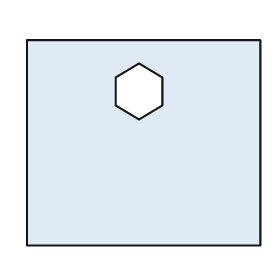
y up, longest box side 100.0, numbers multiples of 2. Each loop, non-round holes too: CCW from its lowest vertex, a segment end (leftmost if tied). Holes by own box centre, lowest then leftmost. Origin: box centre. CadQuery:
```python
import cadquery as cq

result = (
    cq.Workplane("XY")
    .moveTo(-50.0, -44.0)
    .lineTo(50.0, -44.0)
    .lineTo(50.0, 44.0)
    .lineTo(-50.0, 44.0)
    .close()
    .moveTo(-2.0, 10.0)
    .lineTo(8.0, 16.0)
    .lineTo(8.0, 28.0)
    .lineTo(-2.0, 34.0)
    .lineTo(-12.0, 28.0)
    .lineTo(-12.0, 16.0)
    .close()
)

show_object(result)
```